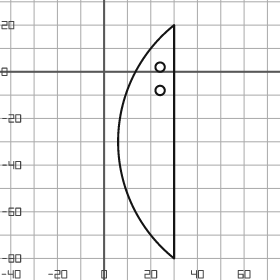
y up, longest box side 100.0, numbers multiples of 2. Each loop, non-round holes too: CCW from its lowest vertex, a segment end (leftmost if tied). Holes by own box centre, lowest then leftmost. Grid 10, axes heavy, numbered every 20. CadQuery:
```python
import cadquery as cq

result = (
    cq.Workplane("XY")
    .moveTo(30.0, -80.0)
    .lineTo(30.0, 20.0)
    .threePointArc((6.0, -30.0), (30.0, -80.0))
    .close()
    .moveTo(24.0, -8.0)
    .circle(2.0)
    .moveTo(24.0, 2.0)
    .circle(2.0)
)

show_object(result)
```